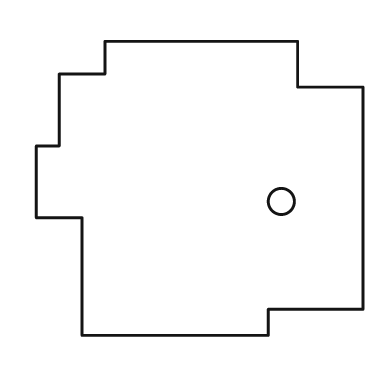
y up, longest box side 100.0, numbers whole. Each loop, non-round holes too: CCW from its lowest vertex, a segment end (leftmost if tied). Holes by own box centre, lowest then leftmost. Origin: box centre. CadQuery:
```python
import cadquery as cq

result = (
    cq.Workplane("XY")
    .moveTo(-36.0, -45.0)
    .lineTo(21.0, -45.0)
    .lineTo(21.0, -37.0)
    .lineTo(50.0, -37.0)
    .lineTo(50.0, 31.0)
    .lineTo(30.0, 31.0)
    .lineTo(30.0, 45.0)
    .lineTo(-29.0, 45.0)
    .lineTo(-29.0, 35.0)
    .lineTo(-43.0, 35.0)
    .lineTo(-43.0, 13.0)
    .lineTo(-50.0, 13.0)
    .lineTo(-50.0, -9.0)
    .lineTo(-36.0, -9.0)
    .close()
    .moveTo(25.0, -4.0)
    .circle(4.0)
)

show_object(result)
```